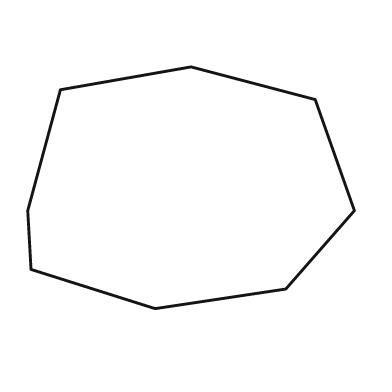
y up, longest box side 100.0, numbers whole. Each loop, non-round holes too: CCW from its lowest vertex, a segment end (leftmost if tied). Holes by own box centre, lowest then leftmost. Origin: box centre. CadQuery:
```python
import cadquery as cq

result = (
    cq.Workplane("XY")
    .moveTo(-11.0, -37.0)
    .lineTo(29.0, -31.0)
    .lineTo(50.0, -7.0)
    .lineTo(38.0, 27.0)
    .lineTo(0.0, 37.0)
    .lineTo(-40.0, 30.0)
    .lineTo(-50.0, -7.0)
    .lineTo(-49.0, -25.0)
    .close()
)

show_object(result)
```